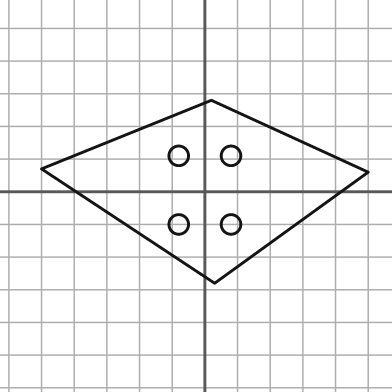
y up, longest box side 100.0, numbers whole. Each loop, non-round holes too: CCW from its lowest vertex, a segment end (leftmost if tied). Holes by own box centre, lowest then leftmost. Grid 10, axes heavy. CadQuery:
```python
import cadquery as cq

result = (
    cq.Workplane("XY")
    .moveTo(3.0, -28.0)
    .lineTo(50.0, 6.0)
    .lineTo(2.0, 28.0)
    .lineTo(-50.0, 7.0)
    .close()
    .moveTo(-8.0, -10.0)
    .circle(3.0)
    .moveTo(8.0, -10.0)
    .circle(3.0)
    .moveTo(-8.0, 11.0)
    .circle(3.0)
    .moveTo(8.0, 11.0)
    .circle(3.0)
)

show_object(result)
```